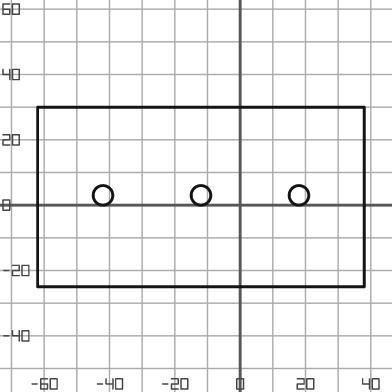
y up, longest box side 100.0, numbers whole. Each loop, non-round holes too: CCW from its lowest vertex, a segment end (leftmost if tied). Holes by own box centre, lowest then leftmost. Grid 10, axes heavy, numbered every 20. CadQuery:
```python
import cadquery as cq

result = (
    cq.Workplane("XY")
    .moveTo(-62.0, -25.0)
    .lineTo(38.0, -25.0)
    .lineTo(38.0, 30.0)
    .lineTo(-62.0, 30.0)
    .close()
    .moveTo(-42.0, 3.0)
    .circle(3.0)
    .moveTo(-12.0, 3.0)
    .circle(3.0)
    .moveTo(18.0, 3.0)
    .circle(3.0)
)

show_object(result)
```